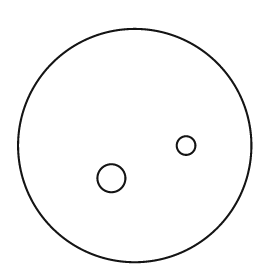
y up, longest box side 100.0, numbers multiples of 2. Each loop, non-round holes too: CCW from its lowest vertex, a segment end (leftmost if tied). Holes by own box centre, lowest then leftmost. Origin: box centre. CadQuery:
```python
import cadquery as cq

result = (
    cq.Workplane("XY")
    .moveTo(0.0, 0.0)
    .circle(50.0)
    .moveTo(-10.0, -14.0)
    .circle(6.0)
    .moveTo(22.0, 0.0)
    .circle(4.0)
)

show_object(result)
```